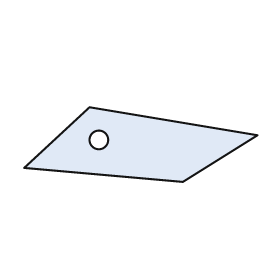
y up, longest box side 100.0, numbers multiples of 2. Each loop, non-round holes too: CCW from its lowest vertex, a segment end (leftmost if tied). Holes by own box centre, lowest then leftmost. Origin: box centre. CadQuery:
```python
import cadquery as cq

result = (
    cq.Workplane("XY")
    .moveTo(18.0, -16.0)
    .lineTo(50.0, 4.0)
    .lineTo(-22.0, 16.0)
    .lineTo(-50.0, -10.0)
    .close()
    .moveTo(-18.0, 2.0)
    .circle(4.0)
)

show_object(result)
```